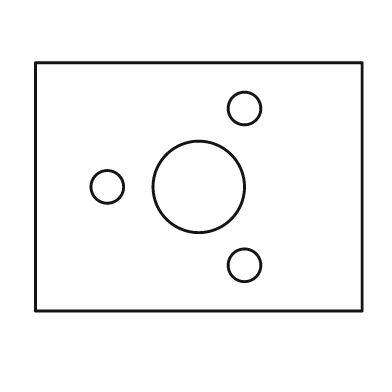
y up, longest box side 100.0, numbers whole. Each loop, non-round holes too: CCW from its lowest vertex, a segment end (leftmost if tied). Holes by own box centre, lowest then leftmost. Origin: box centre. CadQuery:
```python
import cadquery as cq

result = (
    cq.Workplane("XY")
    .moveTo(-50.0, -38.0)
    .lineTo(50.0, -38.0)
    .lineTo(50.0, 38.0)
    .lineTo(-50.0, 38.0)
    .close()
    .moveTo(14.0, -24.0)
    .circle(5.0)
    .moveTo(-28.0, 0.0)
    .circle(5.0)
    .moveTo(0.0, 0.0)
    .circle(14.0)
    .moveTo(14.0, 24.0)
    .circle(5.0)
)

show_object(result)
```